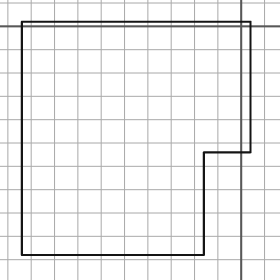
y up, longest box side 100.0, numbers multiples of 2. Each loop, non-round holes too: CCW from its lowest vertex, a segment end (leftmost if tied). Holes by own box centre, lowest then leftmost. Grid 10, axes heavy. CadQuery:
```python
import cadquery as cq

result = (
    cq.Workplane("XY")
    .moveTo(-94.0, -98.0)
    .lineTo(-16.0, -98.0)
    .lineTo(-16.0, -54.0)
    .lineTo(4.0, -54.0)
    .lineTo(4.0, 2.0)
    .lineTo(-94.0, 2.0)
    .close()
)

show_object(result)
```